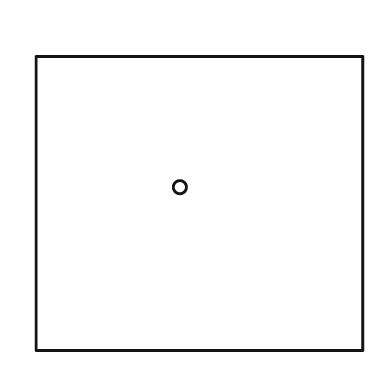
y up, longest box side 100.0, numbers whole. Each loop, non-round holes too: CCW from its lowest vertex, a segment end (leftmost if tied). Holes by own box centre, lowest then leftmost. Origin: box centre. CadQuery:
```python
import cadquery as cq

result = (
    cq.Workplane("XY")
    .moveTo(-50.0, -45.0)
    .lineTo(50.0, -45.0)
    .lineTo(50.0, 45.0)
    .lineTo(-50.0, 45.0)
    .close()
    .moveTo(-6.0, 5.0)
    .circle(2.0)
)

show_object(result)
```